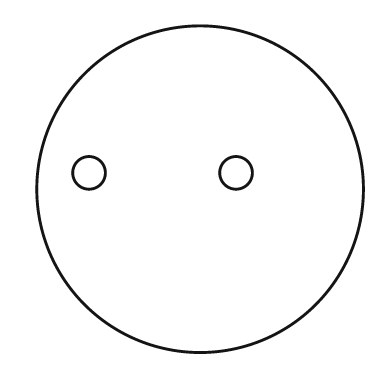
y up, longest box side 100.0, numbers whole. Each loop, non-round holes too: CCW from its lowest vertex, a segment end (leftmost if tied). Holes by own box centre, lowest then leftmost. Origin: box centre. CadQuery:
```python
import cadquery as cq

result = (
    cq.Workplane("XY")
    .moveTo(0.0, 0.0)
    .circle(50.0)
    .moveTo(-34.0, 5.0)
    .circle(5.0)
    .moveTo(11.0, 5.0)
    .circle(5.0)
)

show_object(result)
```